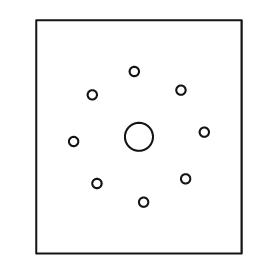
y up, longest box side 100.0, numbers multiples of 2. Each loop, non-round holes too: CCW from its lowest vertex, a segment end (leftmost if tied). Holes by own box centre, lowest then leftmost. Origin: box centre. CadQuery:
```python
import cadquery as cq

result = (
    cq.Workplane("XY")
    .moveTo(-44.0, -50.0)
    .lineTo(44.0, -50.0)
    .lineTo(44.0, 50.0)
    .lineTo(-44.0, 50.0)
    .close()
    .moveTo(2.0, -28.0)
    .circle(2.0)
    .moveTo(-18.0, -20.0)
    .circle(2.0)
    .moveTo(20.0, -18.0)
    .circle(2.0)
    .moveTo(-28.0, -2.0)
    .circle(2.0)
    .moveTo(0.0, 0.0)
    .circle(6.0)
    .moveTo(28.0, 2.0)
    .circle(2.0)
    .moveTo(-20.0, 18.0)
    .circle(2.0)
    .moveTo(18.0, 20.0)
    .circle(2.0)
    .moveTo(-2.0, 28.0)
    .circle(2.0)
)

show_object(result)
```